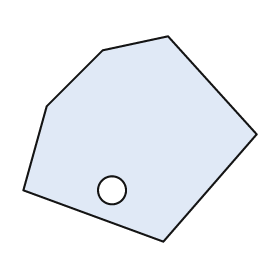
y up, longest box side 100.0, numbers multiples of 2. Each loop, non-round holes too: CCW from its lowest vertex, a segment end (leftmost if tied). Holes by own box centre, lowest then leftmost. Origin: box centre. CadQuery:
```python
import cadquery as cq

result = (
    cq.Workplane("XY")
    .moveTo(10.0, -44.0)
    .lineTo(50.0, 2.0)
    .lineTo(12.0, 44.0)
    .lineTo(-16.0, 38.0)
    .lineTo(-40.0, 14.0)
    .lineTo(-50.0, -22.0)
    .close()
    .moveTo(-12.0, -22.0)
    .circle(6.0)
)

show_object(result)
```